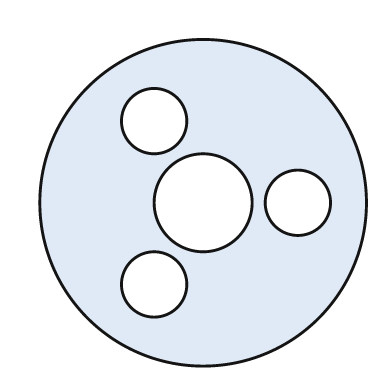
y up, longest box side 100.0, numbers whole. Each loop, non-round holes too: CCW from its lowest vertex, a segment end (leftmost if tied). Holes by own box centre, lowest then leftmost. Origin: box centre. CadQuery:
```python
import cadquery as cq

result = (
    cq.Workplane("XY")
    .moveTo(0.0, 0.0)
    .circle(50.0)
    .moveTo(-15.0, -25.0)
    .circle(10.0)
    .moveTo(0.0, 0.0)
    .circle(15.0)
    .moveTo(29.0, 0.0)
    .circle(10.0)
    .moveTo(-15.0, 25.0)
    .circle(10.0)
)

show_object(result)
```